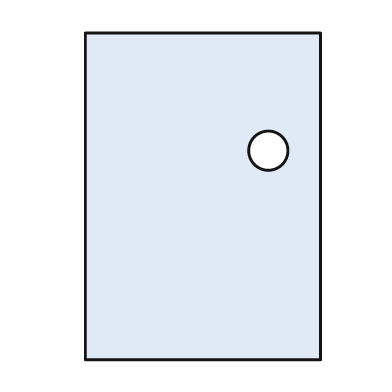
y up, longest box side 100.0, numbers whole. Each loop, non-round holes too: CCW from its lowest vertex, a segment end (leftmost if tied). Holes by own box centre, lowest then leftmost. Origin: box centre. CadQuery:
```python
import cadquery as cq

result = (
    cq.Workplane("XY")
    .moveTo(-36.0, -50.0)
    .lineTo(36.0, -50.0)
    .lineTo(36.0, 50.0)
    .lineTo(-36.0, 50.0)
    .close()
    .moveTo(20.0, 14.0)
    .circle(6.0)
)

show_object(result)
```